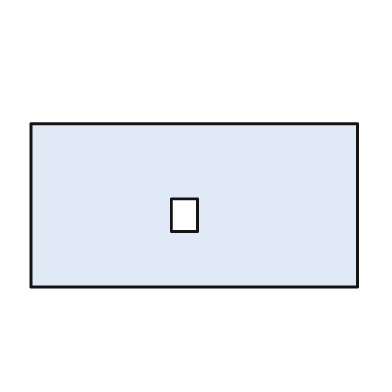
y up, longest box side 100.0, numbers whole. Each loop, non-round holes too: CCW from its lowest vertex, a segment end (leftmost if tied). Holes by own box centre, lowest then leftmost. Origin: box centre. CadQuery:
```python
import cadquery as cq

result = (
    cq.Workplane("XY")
    .moveTo(-50.0, -25.0)
    .lineTo(50.0, -25.0)
    .lineTo(50.0, 25.0)
    .lineTo(-50.0, 25.0)
    .close()
    .moveTo(-7.0, -8.0)
    .lineTo(1.0, -8.0)
    .lineTo(1.0, 2.0)
    .lineTo(-7.0, 2.0)
    .close()
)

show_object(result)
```